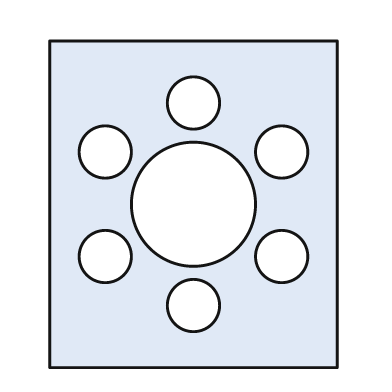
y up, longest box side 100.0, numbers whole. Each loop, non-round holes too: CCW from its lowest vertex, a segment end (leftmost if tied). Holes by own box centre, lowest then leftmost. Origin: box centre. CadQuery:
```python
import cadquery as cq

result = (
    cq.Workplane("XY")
    .moveTo(-44.0, -50.0)
    .lineTo(44.0, -50.0)
    .lineTo(44.0, 50.0)
    .lineTo(-44.0, 50.0)
    .close()
    .moveTo(0.0, -31.0)
    .circle(8.0)
    .moveTo(-27.0, -16.0)
    .circle(8.0)
    .moveTo(27.0, -16.0)
    .circle(8.0)
    .moveTo(0.0, 0.0)
    .circle(19.0)
    .moveTo(-27.0, 16.0)
    .circle(8.0)
    .moveTo(27.0, 16.0)
    .circle(8.0)
    .moveTo(0.0, 31.0)
    .circle(8.0)
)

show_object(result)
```